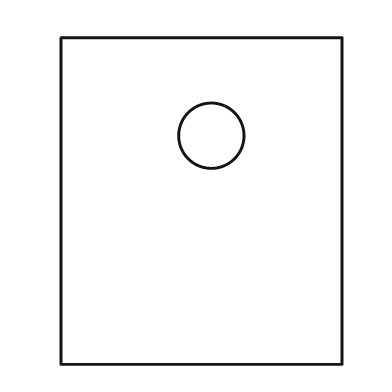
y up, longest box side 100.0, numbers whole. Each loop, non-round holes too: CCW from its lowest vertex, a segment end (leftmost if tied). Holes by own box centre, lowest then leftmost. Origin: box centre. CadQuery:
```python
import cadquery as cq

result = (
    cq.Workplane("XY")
    .moveTo(-43.0, -50.0)
    .lineTo(43.0, -50.0)
    .lineTo(43.0, 50.0)
    .lineTo(-43.0, 50.0)
    .close()
    .moveTo(3.0, 20.0)
    .circle(10.0)
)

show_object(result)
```